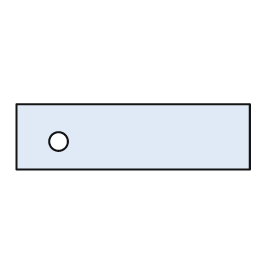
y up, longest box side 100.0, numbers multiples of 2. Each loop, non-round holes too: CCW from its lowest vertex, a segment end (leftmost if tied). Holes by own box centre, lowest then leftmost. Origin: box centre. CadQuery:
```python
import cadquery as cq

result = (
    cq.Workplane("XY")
    .moveTo(-50.0, -14.0)
    .lineTo(50.0, -14.0)
    .lineTo(50.0, 14.0)
    .lineTo(-50.0, 14.0)
    .close()
    .moveTo(-32.0, -2.0)
    .circle(4.0)
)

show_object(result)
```